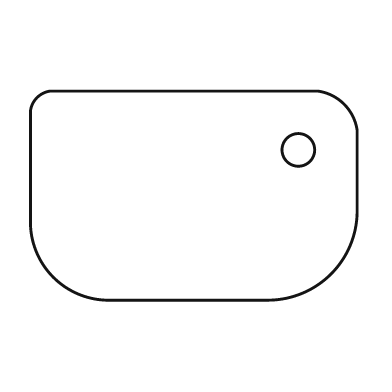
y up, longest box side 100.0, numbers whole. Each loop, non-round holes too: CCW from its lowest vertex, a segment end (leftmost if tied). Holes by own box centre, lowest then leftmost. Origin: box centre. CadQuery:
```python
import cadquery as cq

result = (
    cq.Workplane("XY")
    .moveTo(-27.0, -32.0)
    .lineTo(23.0, -32.0)
    .threePointArc((42.0, -24.0), (50.0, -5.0))
    .lineTo(50.0, 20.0)
    .threePointArc((46.0, 28.0), (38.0, 32.0))
    .lineTo(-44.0, 32.0)
    .threePointArc((-48.0, 30.0), (-50.0, 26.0))
    .lineTo(-50.0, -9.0)
    .threePointArc((-43.0, -25.0), (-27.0, -32.0))
    .close()
    .moveTo(32.0, 14.0)
    .circle(5.0)
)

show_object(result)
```